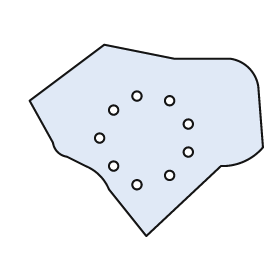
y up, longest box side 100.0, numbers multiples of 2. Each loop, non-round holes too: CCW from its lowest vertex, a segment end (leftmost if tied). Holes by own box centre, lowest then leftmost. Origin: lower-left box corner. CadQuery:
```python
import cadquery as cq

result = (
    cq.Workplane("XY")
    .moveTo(50.0, 0.0)
    .lineTo(82.0, 30.0)
    .threePointArc((92.0, 32.0), (100.0, 38.0))
    .lineTo(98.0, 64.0)
    .threePointArc((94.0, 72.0), (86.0, 76.0))
    .lineTo(62.0, 76.0)
    .lineTo(32.0, 82.0)
    .lineTo(0.0, 58.0)
    .lineTo(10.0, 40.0)
    .threePointArc((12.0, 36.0), (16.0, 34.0))
    .lineTo(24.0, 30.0)
    .threePointArc((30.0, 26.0), (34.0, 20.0))
    .close()
    .moveTo(46.0, 22.0)
    .circle(2.0)
    .moveTo(60.0, 26.0)
    .circle(2.0)
    .moveTo(36.0, 30.0)
    .circle(2.0)
    .moveTo(68.0, 36.0)
    .circle(2.0)
    .moveTo(30.0, 42.0)
    .circle(2.0)
    .moveTo(68.0, 48.0)
    .circle(2.0)
    .moveTo(36.0, 54.0)
    .circle(2.0)
    .moveTo(60.0, 58.0)
    .circle(2.0)
    .moveTo(46.0, 60.0)
    .circle(2.0)
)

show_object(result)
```